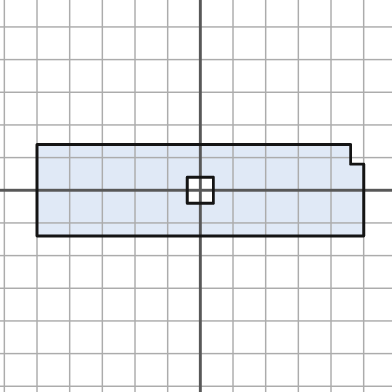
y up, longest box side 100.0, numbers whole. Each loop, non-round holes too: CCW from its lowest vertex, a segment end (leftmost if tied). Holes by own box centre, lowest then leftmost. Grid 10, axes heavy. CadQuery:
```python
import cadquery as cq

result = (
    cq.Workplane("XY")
    .moveTo(-50.0, -14.0)
    .lineTo(50.0, -14.0)
    .lineTo(50.0, 8.0)
    .lineTo(46.0, 8.0)
    .lineTo(46.0, 14.0)
    .lineTo(-50.0, 14.0)
    .close()
    .moveTo(-4.0, -4.0)
    .lineTo(4.0, -4.0)
    .lineTo(4.0, 4.0)
    .lineTo(-4.0, 4.0)
    .close()
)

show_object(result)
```